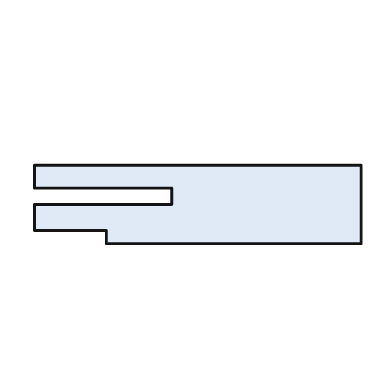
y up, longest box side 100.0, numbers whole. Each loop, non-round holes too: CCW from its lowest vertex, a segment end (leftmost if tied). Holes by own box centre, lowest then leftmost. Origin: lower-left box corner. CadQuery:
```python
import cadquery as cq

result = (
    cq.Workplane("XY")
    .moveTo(22.0, 0.0)
    .lineTo(100.0, 0.0)
    .lineTo(100.0, 24.0)
    .lineTo(0.0, 24.0)
    .lineTo(0.0, 17.0)
    .lineTo(42.0, 17.0)
    .lineTo(42.0, 12.0)
    .lineTo(0.0, 12.0)
    .lineTo(0.0, 4.0)
    .lineTo(22.0, 4.0)
    .close()
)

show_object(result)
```